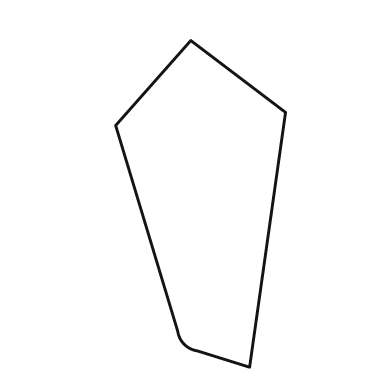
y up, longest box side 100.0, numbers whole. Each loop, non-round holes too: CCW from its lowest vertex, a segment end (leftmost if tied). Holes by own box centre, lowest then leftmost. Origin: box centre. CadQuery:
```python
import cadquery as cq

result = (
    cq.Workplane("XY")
    .moveTo(15.0, -50.0)
    .lineTo(26.0, 28.0)
    .lineTo(-3.0, 50.0)
    .lineTo(-26.0, 24.0)
    .lineTo(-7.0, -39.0)
    .threePointArc((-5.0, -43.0), (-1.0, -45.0))
    .close()
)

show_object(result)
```